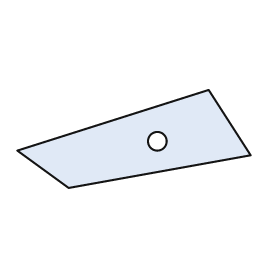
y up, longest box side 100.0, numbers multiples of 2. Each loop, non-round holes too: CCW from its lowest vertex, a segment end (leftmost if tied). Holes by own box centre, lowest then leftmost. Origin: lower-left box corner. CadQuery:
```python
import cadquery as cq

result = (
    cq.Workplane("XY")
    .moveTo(22.0, 0.0)
    .lineTo(100.0, 14.0)
    .lineTo(82.0, 42.0)
    .lineTo(0.0, 16.0)
    .close()
    .moveTo(60.0, 20.0)
    .circle(4.0)
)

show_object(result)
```